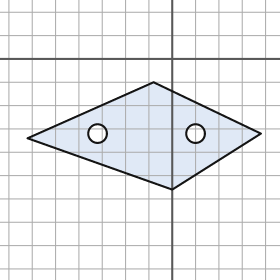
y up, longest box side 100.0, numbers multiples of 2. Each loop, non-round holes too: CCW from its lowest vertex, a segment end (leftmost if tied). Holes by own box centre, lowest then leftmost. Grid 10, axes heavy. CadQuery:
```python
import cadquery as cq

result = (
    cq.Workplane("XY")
    .moveTo(0.0, -56.0)
    .lineTo(38.0, -32.0)
    .lineTo(-8.0, -10.0)
    .lineTo(-62.0, -34.0)
    .close()
    .moveTo(-32.0, -32.0)
    .circle(4.0)
    .moveTo(10.0, -32.0)
    .circle(4.0)
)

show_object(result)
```